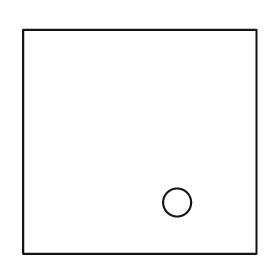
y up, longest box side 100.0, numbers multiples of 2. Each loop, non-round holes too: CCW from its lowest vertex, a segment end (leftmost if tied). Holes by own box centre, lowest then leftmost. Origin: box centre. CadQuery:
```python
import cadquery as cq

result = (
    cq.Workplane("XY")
    .moveTo(-50.0, -48.0)
    .lineTo(50.0, -48.0)
    .lineTo(50.0, 48.0)
    .lineTo(-50.0, 48.0)
    .close()
    .moveTo(16.0, -26.0)
    .circle(6.0)
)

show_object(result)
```